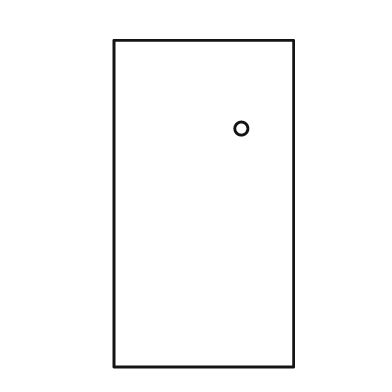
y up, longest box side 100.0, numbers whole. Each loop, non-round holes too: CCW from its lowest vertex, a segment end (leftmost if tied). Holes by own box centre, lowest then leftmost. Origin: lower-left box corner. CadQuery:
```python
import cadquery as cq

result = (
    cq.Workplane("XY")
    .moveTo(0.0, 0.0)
    .lineTo(55.0, 0.0)
    .lineTo(55.0, 100.0)
    .lineTo(0.0, 100.0)
    .close()
    .moveTo(39.0, 73.0)
    .circle(2.0)
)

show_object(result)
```